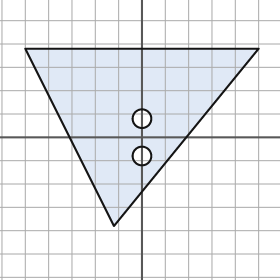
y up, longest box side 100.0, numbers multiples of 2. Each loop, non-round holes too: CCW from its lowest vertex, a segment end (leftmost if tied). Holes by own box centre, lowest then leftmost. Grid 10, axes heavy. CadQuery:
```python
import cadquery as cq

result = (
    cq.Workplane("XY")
    .moveTo(-12.0, -38.0)
    .lineTo(50.0, 38.0)
    .lineTo(-50.0, 38.0)
    .close()
    .moveTo(0.0, -8.0)
    .circle(4.0)
    .moveTo(0.0, 8.0)
    .circle(4.0)
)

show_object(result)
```